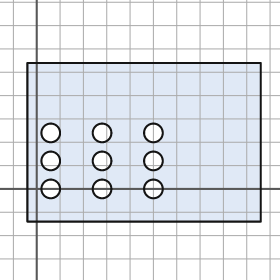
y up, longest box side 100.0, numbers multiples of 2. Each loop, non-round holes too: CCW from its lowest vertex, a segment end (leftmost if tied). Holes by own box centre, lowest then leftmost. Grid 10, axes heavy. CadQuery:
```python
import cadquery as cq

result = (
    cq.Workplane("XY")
    .moveTo(-4.0, -14.0)
    .lineTo(96.0, -14.0)
    .lineTo(96.0, 54.0)
    .lineTo(-4.0, 54.0)
    .close()
    .moveTo(6.0, 0.0)
    .circle(4.0)
    .moveTo(28.0, 0.0)
    .circle(4.0)
    .moveTo(50.0, 0.0)
    .circle(4.0)
    .moveTo(6.0, 12.0)
    .circle(4.0)
    .moveTo(28.0, 12.0)
    .circle(4.0)
    .moveTo(50.0, 12.0)
    .circle(4.0)
    .moveTo(6.0, 24.0)
    .circle(4.0)
    .moveTo(28.0, 24.0)
    .circle(4.0)
    .moveTo(50.0, 24.0)
    .circle(4.0)
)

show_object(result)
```